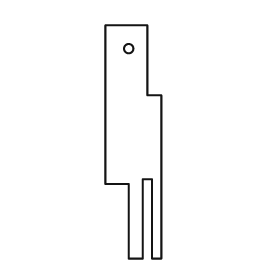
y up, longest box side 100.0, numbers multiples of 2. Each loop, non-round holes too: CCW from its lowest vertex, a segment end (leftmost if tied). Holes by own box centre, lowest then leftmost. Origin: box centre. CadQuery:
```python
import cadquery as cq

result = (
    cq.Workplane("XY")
    .moveTo(-2.0, -50.0)
    .lineTo(4.0, -50.0)
    .lineTo(4.0, -16.0)
    .lineTo(8.0, -16.0)
    .lineTo(8.0, -50.0)
    .lineTo(12.0, -50.0)
    .lineTo(12.0, 20.0)
    .lineTo(6.0, 20.0)
    .lineTo(6.0, 50.0)
    .lineTo(-12.0, 50.0)
    .lineTo(-12.0, -18.0)
    .lineTo(-2.0, -18.0)
    .close()
    .moveTo(-2.0, 40.0)
    .circle(2.0)
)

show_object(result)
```